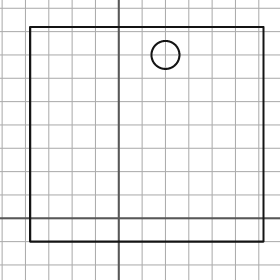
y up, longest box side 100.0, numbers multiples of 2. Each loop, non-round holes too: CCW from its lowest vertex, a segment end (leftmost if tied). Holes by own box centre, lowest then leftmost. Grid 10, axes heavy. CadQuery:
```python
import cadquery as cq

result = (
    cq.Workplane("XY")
    .moveTo(-38.0, -10.0)
    .lineTo(62.0, -10.0)
    .lineTo(62.0, 82.0)
    .lineTo(-38.0, 82.0)
    .close()
    .moveTo(20.0, 70.0)
    .circle(6.0)
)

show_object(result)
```